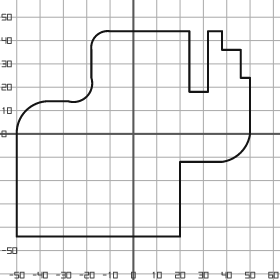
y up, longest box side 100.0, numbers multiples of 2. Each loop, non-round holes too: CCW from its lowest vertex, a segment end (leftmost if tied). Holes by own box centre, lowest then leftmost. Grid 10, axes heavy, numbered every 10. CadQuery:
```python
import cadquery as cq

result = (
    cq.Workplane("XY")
    .moveTo(-50.0, -44.0)
    .lineTo(20.0, -44.0)
    .lineTo(20.0, -12.0)
    .lineTo(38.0, -12.0)
    .threePointArc((46.0, -8.0), (50.0, 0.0))
    .lineTo(50.0, 24.0)
    .lineTo(46.0, 24.0)
    .lineTo(46.0, 36.0)
    .lineTo(38.0, 36.0)
    .lineTo(38.0, 44.0)
    .lineTo(32.0, 44.0)
    .lineTo(32.0, 18.0)
    .lineTo(24.0, 18.0)
    .lineTo(24.0, 44.0)
    .lineTo(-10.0, 44.0)
    .threePointArc((-16.0, 42.0), (-18.0, 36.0))
    .lineTo(-18.0, 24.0)
    .threePointArc((-20.0, 16.0), (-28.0, 14.0))
    .lineTo(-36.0, 14.0)
    .threePointArc((-46.0, 10.0), (-50.0, 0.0))
    .close()
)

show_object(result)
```